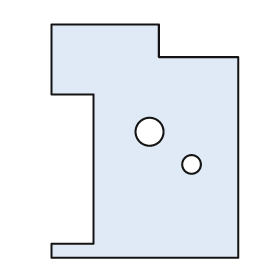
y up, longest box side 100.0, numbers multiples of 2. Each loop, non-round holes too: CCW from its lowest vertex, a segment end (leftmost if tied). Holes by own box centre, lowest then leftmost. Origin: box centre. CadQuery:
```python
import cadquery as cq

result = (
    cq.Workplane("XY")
    .moveTo(-40.0, -50.0)
    .lineTo(40.0, -50.0)
    .lineTo(40.0, 36.0)
    .lineTo(6.0, 36.0)
    .lineTo(6.0, 50.0)
    .lineTo(-40.0, 50.0)
    .lineTo(-40.0, 20.0)
    .lineTo(-22.0, 20.0)
    .lineTo(-22.0, -44.0)
    .lineTo(-40.0, -44.0)
    .close()
    .moveTo(20.0, -10.0)
    .circle(4.0)
    .moveTo(2.0, 4.0)
    .circle(6.0)
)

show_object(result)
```